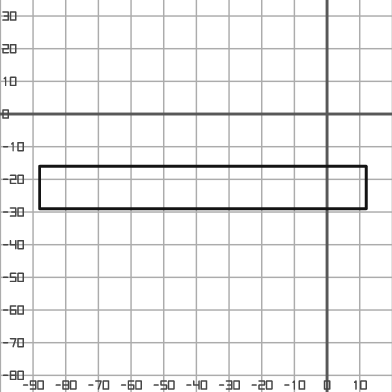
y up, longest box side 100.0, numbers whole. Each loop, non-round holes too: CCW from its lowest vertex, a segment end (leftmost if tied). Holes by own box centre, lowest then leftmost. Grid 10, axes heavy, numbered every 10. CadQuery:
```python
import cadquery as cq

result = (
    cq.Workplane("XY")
    .moveTo(-88.0, -29.0)
    .lineTo(12.0, -29.0)
    .lineTo(12.0, -16.0)
    .lineTo(-88.0, -16.0)
    .close()
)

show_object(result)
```